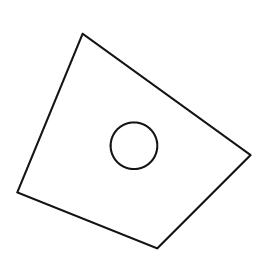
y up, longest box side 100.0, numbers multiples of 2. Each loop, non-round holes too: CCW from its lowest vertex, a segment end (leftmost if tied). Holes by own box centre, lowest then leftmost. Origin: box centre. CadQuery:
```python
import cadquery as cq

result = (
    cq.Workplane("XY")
    .moveTo(10.0, -46.0)
    .lineTo(50.0, -6.0)
    .lineTo(-22.0, 46.0)
    .lineTo(-50.0, -22.0)
    .close()
    .moveTo(0.0, -2.0)
    .circle(10.0)
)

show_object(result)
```